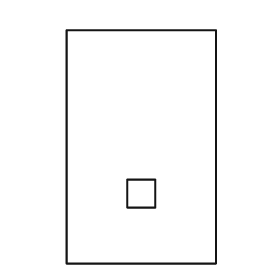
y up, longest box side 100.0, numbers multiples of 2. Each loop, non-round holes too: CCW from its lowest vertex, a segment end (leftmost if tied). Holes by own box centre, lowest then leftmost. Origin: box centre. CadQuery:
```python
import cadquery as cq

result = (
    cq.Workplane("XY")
    .moveTo(-32.0, -50.0)
    .lineTo(32.0, -50.0)
    .lineTo(32.0, 50.0)
    .lineTo(-32.0, 50.0)
    .close()
    .moveTo(-6.0, -26.0)
    .lineTo(6.0, -26.0)
    .lineTo(6.0, -14.0)
    .lineTo(-6.0, -14.0)
    .close()
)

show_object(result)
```